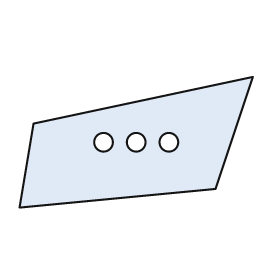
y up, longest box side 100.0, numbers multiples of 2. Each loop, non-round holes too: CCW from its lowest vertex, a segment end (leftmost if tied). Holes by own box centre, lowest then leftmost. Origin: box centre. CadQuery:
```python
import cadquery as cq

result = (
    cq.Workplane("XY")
    .moveTo(-50.0, -28.0)
    .lineTo(34.0, -20.0)
    .lineTo(50.0, 28.0)
    .lineTo(-44.0, 8.0)
    .close()
    .moveTo(-14.0, 0.0)
    .circle(4.0)
    .moveTo(0.0, 0.0)
    .circle(4.0)
    .moveTo(14.0, 0.0)
    .circle(4.0)
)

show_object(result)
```